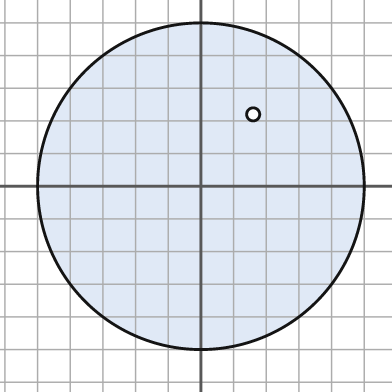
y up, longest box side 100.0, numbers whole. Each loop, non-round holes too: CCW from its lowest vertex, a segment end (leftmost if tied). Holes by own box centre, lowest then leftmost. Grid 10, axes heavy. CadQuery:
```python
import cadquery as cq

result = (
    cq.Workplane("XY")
    .moveTo(0.0, 0.0)
    .circle(50.0)
    .moveTo(16.0, 22.0)
    .circle(2.0)
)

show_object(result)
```